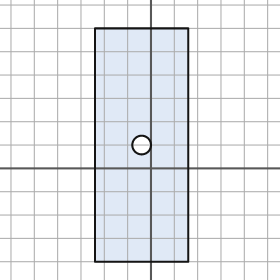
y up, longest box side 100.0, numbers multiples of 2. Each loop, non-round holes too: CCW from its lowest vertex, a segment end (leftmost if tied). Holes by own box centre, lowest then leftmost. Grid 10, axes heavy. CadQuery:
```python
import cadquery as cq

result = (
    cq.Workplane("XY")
    .moveTo(-24.0, -40.0)
    .lineTo(16.0, -40.0)
    .lineTo(16.0, 60.0)
    .lineTo(-24.0, 60.0)
    .close()
    .moveTo(-4.0, 10.0)
    .circle(4.0)
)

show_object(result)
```